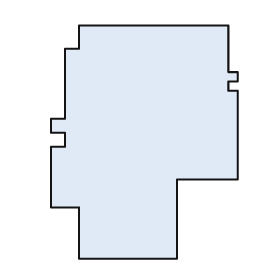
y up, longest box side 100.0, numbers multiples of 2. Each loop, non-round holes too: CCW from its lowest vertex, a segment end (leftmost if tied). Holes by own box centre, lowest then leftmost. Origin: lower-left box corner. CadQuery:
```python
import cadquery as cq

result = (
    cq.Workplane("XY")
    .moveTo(12.0, 0.0)
    .lineTo(54.0, 0.0)
    .lineTo(54.0, 34.0)
    .lineTo(80.0, 34.0)
    .lineTo(80.0, 72.0)
    .lineTo(76.0, 72.0)
    .lineTo(76.0, 76.0)
    .lineTo(80.0, 76.0)
    .lineTo(80.0, 80.0)
    .lineTo(76.0, 80.0)
    .lineTo(76.0, 100.0)
    .lineTo(12.0, 100.0)
    .lineTo(12.0, 90.0)
    .lineTo(6.0, 90.0)
    .lineTo(6.0, 60.0)
    .lineTo(0.0, 60.0)
    .lineTo(0.0, 54.0)
    .lineTo(6.0, 54.0)
    .lineTo(6.0, 48.0)
    .lineTo(0.0, 48.0)
    .lineTo(0.0, 22.0)
    .lineTo(12.0, 22.0)
    .close()
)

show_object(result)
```